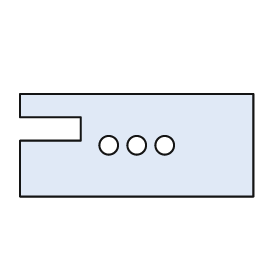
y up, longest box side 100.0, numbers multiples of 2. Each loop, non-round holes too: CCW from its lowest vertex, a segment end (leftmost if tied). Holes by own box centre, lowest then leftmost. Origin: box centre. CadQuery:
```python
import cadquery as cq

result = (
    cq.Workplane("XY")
    .moveTo(-50.0, -22.0)
    .lineTo(50.0, -22.0)
    .lineTo(50.0, 22.0)
    .lineTo(-50.0, 22.0)
    .lineTo(-50.0, 12.0)
    .lineTo(-24.0, 12.0)
    .lineTo(-24.0, 2.0)
    .lineTo(-50.0, 2.0)
    .close()
    .moveTo(-12.0, 0.0)
    .circle(4.0)
    .moveTo(0.0, 0.0)
    .circle(4.0)
    .moveTo(12.0, 0.0)
    .circle(4.0)
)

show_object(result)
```